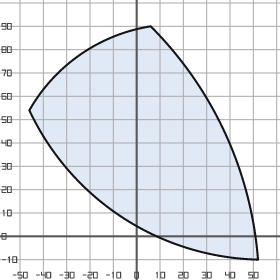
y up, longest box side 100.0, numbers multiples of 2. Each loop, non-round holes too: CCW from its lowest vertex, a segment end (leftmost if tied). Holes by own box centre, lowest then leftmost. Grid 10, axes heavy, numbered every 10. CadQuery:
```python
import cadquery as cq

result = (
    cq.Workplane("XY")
    .moveTo(52.0, -10.0)
    .threePointArc((38.0, 44.0), (6.0, 90.0))
    .threePointArc((-24.0, 78.0), (-46.0, 54.0))
    .threePointArc((-6.0, 8.0), (52.0, -10.0))
    .close()
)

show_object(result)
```